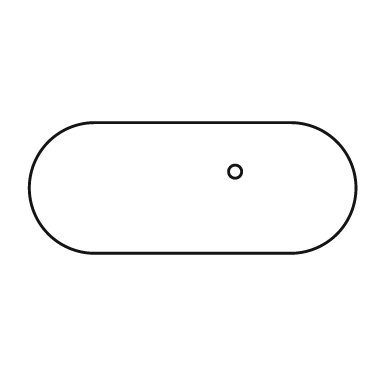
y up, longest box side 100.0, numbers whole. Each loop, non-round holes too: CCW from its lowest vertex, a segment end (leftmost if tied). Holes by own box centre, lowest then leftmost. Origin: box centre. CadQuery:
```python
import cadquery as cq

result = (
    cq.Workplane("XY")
    .moveTo(-30.0, -20.0)
    .lineTo(30.0, -20.0)
    .threePointArc((50.0, 0.0), (30.0, 20.0))
    .lineTo(-30.0, 20.0)
    .threePointArc((-50.0, 0.0), (-30.0, -20.0))
    .close()
    .moveTo(13.0, 5.0)
    .circle(2.0)
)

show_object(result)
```